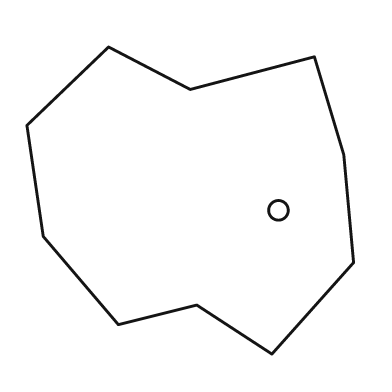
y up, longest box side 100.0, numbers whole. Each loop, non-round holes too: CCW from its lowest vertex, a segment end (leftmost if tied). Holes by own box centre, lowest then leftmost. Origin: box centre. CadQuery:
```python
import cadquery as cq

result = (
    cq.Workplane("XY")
    .moveTo(25.0, -47.0)
    .lineTo(50.0, -19.0)
    .lineTo(47.0, 14.0)
    .lineTo(38.0, 44.0)
    .lineTo(0.0, 34.0)
    .lineTo(-25.0, 47.0)
    .lineTo(-50.0, 23.0)
    .lineTo(-45.0, -11.0)
    .lineTo(-22.0, -38.0)
    .lineTo(2.0, -32.0)
    .close()
    .moveTo(27.0, -3.0)
    .circle(3.0)
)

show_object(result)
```